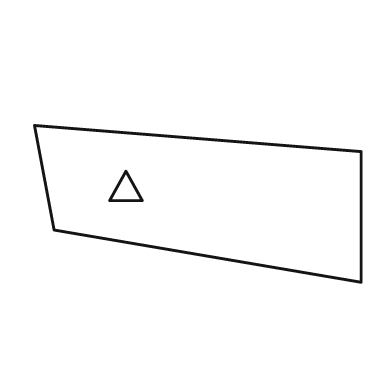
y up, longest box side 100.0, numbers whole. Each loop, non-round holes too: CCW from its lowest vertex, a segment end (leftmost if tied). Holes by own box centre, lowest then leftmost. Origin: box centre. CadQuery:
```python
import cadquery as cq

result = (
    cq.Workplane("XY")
    .moveTo(50.0, -24.0)
    .lineTo(50.0, 16.0)
    .lineTo(-50.0, 24.0)
    .lineTo(-44.0, -8.0)
    .close()
    .moveTo(-27.0, 1.0)
    .lineTo(-17.0, 1.0)
    .lineTo(-22.0, 10.0)
    .close()
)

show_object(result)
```